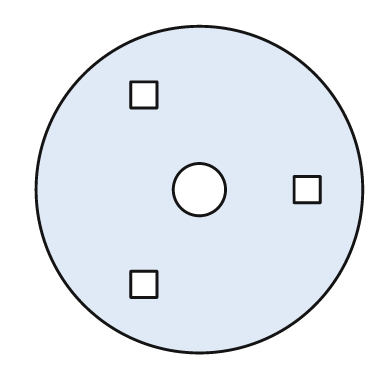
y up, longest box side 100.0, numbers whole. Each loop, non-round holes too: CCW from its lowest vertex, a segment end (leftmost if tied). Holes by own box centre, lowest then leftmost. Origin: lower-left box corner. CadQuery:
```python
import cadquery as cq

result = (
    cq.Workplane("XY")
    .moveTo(50.0, 50.0)
    .circle(50.0)
    .moveTo(29.0, 17.0)
    .lineTo(37.0, 17.0)
    .lineTo(37.0, 25.0)
    .lineTo(29.0, 25.0)
    .close()
    .moveTo(50.0, 50.0)
    .circle(8.0)
    .moveTo(79.0, 46.0)
    .lineTo(87.0, 46.0)
    .lineTo(87.0, 54.0)
    .lineTo(79.0, 54.0)
    .close()
    .moveTo(29.0, 75.0)
    .lineTo(37.0, 75.0)
    .lineTo(37.0, 83.0)
    .lineTo(29.0, 83.0)
    .close()
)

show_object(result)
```